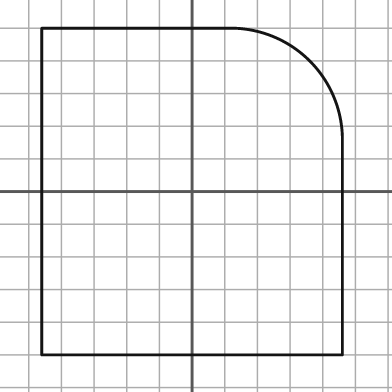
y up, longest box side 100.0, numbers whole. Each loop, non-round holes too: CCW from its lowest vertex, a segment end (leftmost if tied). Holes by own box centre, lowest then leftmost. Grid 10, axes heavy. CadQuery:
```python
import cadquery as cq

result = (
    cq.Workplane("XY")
    .moveTo(-46.0, -50.0)
    .lineTo(46.0, -50.0)
    .lineTo(46.0, 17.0)
    .threePointArc((36.0, 40.0), (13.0, 50.0))
    .lineTo(-46.0, 50.0)
    .close()
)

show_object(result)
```